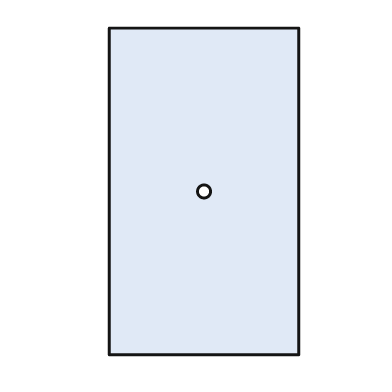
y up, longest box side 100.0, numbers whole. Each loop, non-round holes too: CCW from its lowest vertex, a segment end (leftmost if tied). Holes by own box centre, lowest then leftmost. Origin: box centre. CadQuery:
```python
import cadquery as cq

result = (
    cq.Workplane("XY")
    .moveTo(-29.0, -50.0)
    .lineTo(29.0, -50.0)
    .lineTo(29.0, 50.0)
    .lineTo(-29.0, 50.0)
    .close()
    .moveTo(0.0, 0.0)
    .circle(2.0)
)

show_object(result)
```